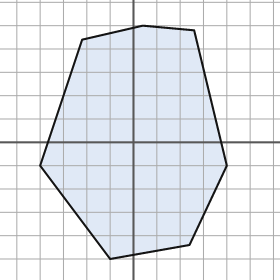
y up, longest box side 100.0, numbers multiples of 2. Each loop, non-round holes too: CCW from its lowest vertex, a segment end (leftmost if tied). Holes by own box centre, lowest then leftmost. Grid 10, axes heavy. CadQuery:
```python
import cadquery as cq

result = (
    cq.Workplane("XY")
    .moveTo(-10.0, -50.0)
    .lineTo(24.0, -44.0)
    .lineTo(40.0, -10.0)
    .lineTo(26.0, 48.0)
    .lineTo(4.0, 50.0)
    .lineTo(-22.0, 44.0)
    .lineTo(-40.0, -10.0)
    .close()
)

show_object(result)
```